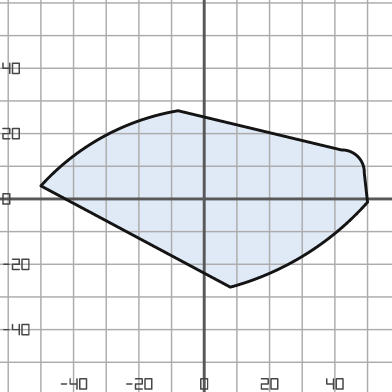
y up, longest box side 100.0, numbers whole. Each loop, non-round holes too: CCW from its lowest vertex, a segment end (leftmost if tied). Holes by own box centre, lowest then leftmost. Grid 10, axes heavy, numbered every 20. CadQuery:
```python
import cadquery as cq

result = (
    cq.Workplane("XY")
    .moveTo(8.0, -27.0)
    .threePointArc((31.0, -17.0), (50.0, -1.0))
    .lineTo(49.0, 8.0)
    .threePointArc((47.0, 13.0), (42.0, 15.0))
    .lineTo(-8.0, 27.0)
    .threePointArc((-31.0, 19.0), (-50.0, 4.0))
    .close()
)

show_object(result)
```